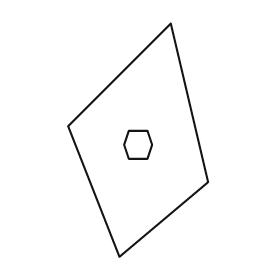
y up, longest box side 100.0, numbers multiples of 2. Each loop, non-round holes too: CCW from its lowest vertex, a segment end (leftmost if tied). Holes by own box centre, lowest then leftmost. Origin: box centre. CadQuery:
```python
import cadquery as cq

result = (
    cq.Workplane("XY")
    .moveTo(-8.0, -50.0)
    .lineTo(30.0, -18.0)
    .lineTo(14.0, 50.0)
    .lineTo(-30.0, 6.0)
    .close()
    .moveTo(-4.0, -8.0)
    .lineTo(4.0, -8.0)
    .lineTo(6.0, -2.0)
    .lineTo(4.0, 4.0)
    .lineTo(-4.0, 4.0)
    .lineTo(-6.0, -2.0)
    .close()
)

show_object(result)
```